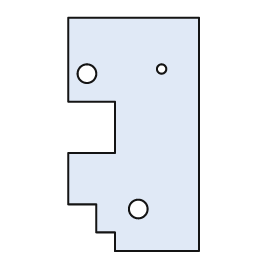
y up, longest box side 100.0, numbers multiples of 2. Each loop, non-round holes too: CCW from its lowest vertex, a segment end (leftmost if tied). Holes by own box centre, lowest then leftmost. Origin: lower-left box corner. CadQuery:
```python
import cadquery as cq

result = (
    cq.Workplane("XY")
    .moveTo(20.0, 0.0)
    .lineTo(56.0, 0.0)
    .lineTo(56.0, 100.0)
    .lineTo(0.0, 100.0)
    .lineTo(0.0, 64.0)
    .lineTo(20.0, 64.0)
    .lineTo(20.0, 42.0)
    .lineTo(0.0, 42.0)
    .lineTo(0.0, 20.0)
    .lineTo(12.0, 20.0)
    .lineTo(12.0, 8.0)
    .lineTo(20.0, 8.0)
    .close()
    .moveTo(30.0, 18.0)
    .circle(4.0)
    .moveTo(8.0, 76.0)
    .circle(4.0)
    .moveTo(40.0, 78.0)
    .circle(2.0)
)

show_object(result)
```